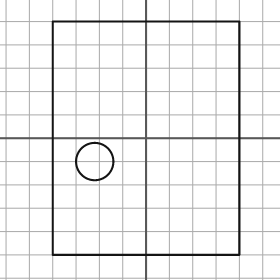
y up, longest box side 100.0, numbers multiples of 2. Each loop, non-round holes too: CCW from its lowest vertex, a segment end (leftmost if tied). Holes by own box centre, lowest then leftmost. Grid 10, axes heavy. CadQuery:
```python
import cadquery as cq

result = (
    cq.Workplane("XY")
    .moveTo(-40.0, -50.0)
    .lineTo(40.0, -50.0)
    .lineTo(40.0, 50.0)
    .lineTo(-40.0, 50.0)
    .close()
    .moveTo(-22.0, -10.0)
    .circle(8.0)
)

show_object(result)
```